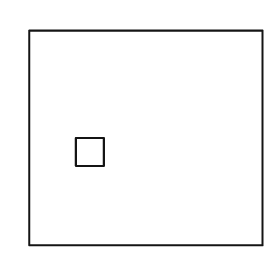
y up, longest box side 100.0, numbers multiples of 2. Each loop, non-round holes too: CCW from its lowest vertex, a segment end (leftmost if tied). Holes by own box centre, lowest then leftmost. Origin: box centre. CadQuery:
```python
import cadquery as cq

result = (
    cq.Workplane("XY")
    .moveTo(-50.0, -46.0)
    .lineTo(50.0, -46.0)
    .lineTo(50.0, 46.0)
    .lineTo(-50.0, 46.0)
    .close()
    .moveTo(-30.0, -12.0)
    .lineTo(-18.0, -12.0)
    .lineTo(-18.0, 0.0)
    .lineTo(-30.0, 0.0)
    .close()
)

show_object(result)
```